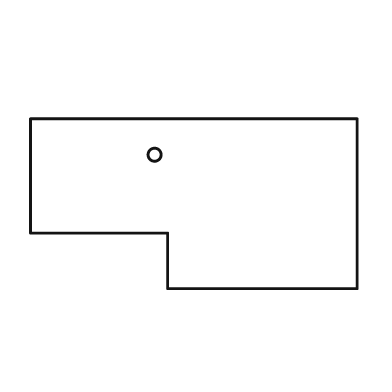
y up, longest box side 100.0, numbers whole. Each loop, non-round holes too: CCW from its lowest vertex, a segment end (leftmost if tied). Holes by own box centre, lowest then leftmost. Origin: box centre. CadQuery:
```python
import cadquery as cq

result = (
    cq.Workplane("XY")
    .moveTo(-8.0, -26.0)
    .lineTo(50.0, -26.0)
    .lineTo(50.0, 26.0)
    .lineTo(-50.0, 26.0)
    .lineTo(-50.0, -9.0)
    .lineTo(-8.0, -9.0)
    .close()
    .moveTo(-12.0, 15.0)
    .circle(2.0)
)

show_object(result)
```